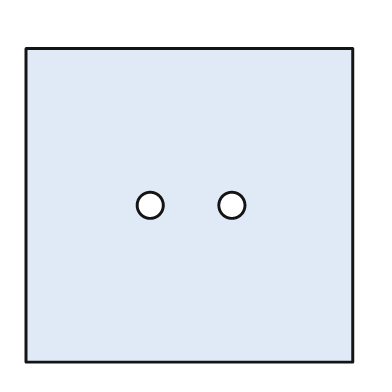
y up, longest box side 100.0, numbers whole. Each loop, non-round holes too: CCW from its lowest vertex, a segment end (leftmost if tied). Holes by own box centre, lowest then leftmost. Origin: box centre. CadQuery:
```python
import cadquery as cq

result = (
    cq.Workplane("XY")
    .moveTo(-50.0, -48.0)
    .lineTo(50.0, -48.0)
    .lineTo(50.0, 48.0)
    .lineTo(-50.0, 48.0)
    .close()
    .moveTo(-12.0, 0.0)
    .circle(4.0)
    .moveTo(13.0, 0.0)
    .circle(4.0)
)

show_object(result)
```